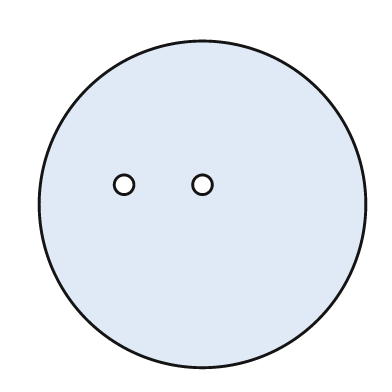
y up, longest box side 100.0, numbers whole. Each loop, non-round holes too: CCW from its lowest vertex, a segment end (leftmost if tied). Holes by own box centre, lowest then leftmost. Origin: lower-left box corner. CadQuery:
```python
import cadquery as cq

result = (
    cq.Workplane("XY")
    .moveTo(50.0, 50.0)
    .circle(50.0)
    .moveTo(26.0, 56.0)
    .circle(3.0)
    .moveTo(50.0, 56.0)
    .circle(3.0)
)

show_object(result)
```